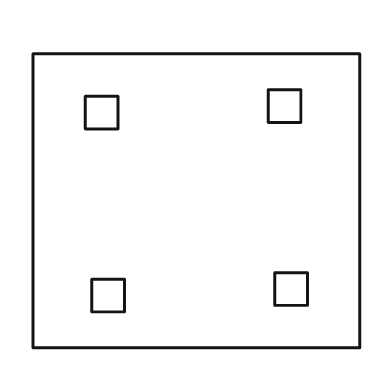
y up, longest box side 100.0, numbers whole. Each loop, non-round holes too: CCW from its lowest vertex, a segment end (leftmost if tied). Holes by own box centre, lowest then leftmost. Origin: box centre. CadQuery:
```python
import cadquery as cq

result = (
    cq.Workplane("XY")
    .moveTo(-50.0, -45.0)
    .lineTo(50.0, -45.0)
    .lineTo(50.0, 45.0)
    .lineTo(-50.0, 45.0)
    .close()
    .moveTo(-32.0, -34.0)
    .lineTo(-22.0, -34.0)
    .lineTo(-22.0, -24.0)
    .lineTo(-32.0, -24.0)
    .close()
    .moveTo(24.0, -32.0)
    .lineTo(34.0, -32.0)
    .lineTo(34.0, -22.0)
    .lineTo(24.0, -22.0)
    .close()
    .moveTo(-34.0, 22.0)
    .lineTo(-24.0, 22.0)
    .lineTo(-24.0, 32.0)
    .lineTo(-34.0, 32.0)
    .close()
    .moveTo(22.0, 24.0)
    .lineTo(32.0, 24.0)
    .lineTo(32.0, 34.0)
    .lineTo(22.0, 34.0)
    .close()
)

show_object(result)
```